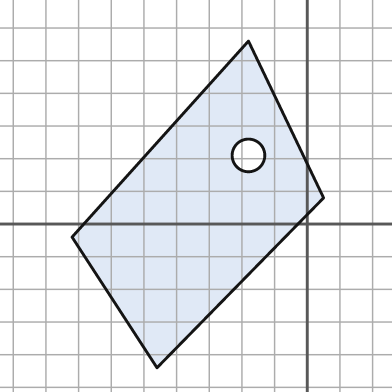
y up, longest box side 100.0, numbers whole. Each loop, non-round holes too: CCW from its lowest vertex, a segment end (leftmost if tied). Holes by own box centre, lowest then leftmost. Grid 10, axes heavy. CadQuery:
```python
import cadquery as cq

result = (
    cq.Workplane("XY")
    .moveTo(-46.0, -44.0)
    .lineTo(5.0, 8.0)
    .lineTo(-18.0, 56.0)
    .lineTo(-72.0, -4.0)
    .close()
    .moveTo(-18.0, 21.0)
    .circle(5.0)
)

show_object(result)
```